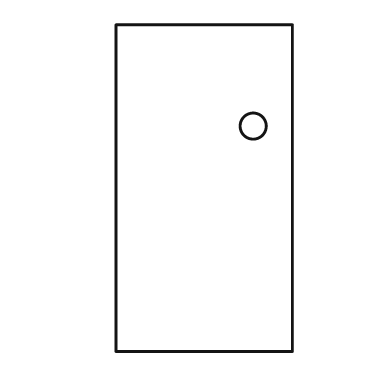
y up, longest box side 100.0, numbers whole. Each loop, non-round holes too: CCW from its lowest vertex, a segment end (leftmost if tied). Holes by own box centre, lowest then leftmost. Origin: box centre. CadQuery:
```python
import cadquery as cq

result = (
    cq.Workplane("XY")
    .moveTo(-27.0, -50.0)
    .lineTo(27.0, -50.0)
    .lineTo(27.0, 50.0)
    .lineTo(-27.0, 50.0)
    .close()
    .moveTo(15.0, 19.0)
    .circle(4.0)
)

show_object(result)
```